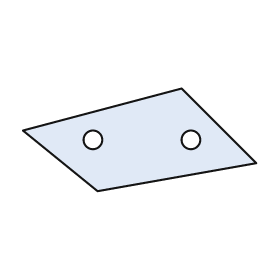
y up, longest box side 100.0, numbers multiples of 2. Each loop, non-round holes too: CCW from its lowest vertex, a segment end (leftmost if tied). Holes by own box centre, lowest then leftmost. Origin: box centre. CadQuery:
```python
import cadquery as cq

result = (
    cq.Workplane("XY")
    .moveTo(-18.0, -22.0)
    .lineTo(50.0, -10.0)
    .lineTo(18.0, 22.0)
    .lineTo(-50.0, 4.0)
    .close()
    .moveTo(-20.0, 0.0)
    .circle(4.0)
    .moveTo(22.0, 0.0)
    .circle(4.0)
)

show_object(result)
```